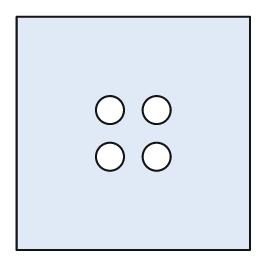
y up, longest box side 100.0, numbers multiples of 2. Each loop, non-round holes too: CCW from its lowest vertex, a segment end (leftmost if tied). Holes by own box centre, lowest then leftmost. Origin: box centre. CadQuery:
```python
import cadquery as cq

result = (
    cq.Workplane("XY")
    .moveTo(-50.0, -50.0)
    .lineTo(50.0, -50.0)
    .lineTo(50.0, 50.0)
    .lineTo(-50.0, 50.0)
    .close()
    .moveTo(-10.0, -10.0)
    .circle(6.0)
    .moveTo(10.0, -10.0)
    .circle(6.0)
    .moveTo(-10.0, 10.0)
    .circle(6.0)
    .moveTo(10.0, 10.0)
    .circle(6.0)
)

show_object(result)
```